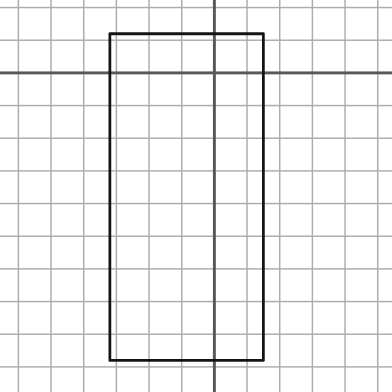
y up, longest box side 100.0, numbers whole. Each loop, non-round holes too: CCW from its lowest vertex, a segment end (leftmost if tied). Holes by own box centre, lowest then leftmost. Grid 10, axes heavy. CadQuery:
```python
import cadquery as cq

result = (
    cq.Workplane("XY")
    .moveTo(-32.0, -88.0)
    .lineTo(15.0, -88.0)
    .lineTo(15.0, 12.0)
    .lineTo(-32.0, 12.0)
    .close()
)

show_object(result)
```